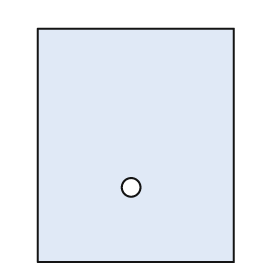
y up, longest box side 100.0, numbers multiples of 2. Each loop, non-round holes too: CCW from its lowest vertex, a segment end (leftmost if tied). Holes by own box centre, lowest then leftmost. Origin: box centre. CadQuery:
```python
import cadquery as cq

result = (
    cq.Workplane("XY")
    .moveTo(-42.0, -50.0)
    .lineTo(42.0, -50.0)
    .lineTo(42.0, 50.0)
    .lineTo(-42.0, 50.0)
    .close()
    .moveTo(-2.0, -18.0)
    .circle(4.0)
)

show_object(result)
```